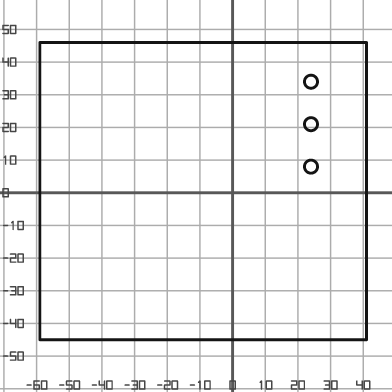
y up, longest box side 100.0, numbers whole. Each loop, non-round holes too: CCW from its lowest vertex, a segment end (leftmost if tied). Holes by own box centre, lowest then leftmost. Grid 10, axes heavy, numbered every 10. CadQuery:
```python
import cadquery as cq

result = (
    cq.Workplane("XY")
    .moveTo(-59.0, -45.0)
    .lineTo(41.0, -45.0)
    .lineTo(41.0, 46.0)
    .lineTo(-59.0, 46.0)
    .close()
    .moveTo(24.0, 8.0)
    .circle(2.0)
    .moveTo(24.0, 21.0)
    .circle(2.0)
    .moveTo(24.0, 34.0)
    .circle(2.0)
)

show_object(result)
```